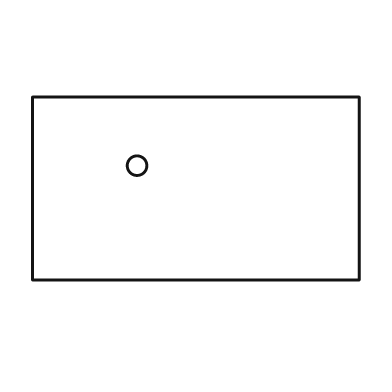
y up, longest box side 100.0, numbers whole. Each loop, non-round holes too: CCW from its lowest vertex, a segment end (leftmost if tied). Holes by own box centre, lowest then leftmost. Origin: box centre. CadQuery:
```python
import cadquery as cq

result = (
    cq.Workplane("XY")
    .moveTo(-50.0, -28.0)
    .lineTo(50.0, -28.0)
    .lineTo(50.0, 28.0)
    .lineTo(-50.0, 28.0)
    .close()
    .moveTo(-18.0, 7.0)
    .circle(3.0)
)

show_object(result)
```